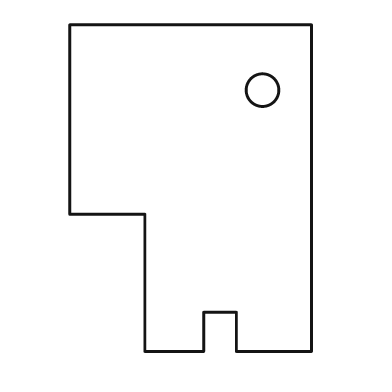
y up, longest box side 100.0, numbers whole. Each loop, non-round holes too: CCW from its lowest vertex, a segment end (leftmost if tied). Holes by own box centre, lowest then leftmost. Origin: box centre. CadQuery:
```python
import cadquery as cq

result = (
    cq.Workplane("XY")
    .moveTo(-14.0, -50.0)
    .lineTo(4.0, -50.0)
    .lineTo(4.0, -38.0)
    .lineTo(14.0, -38.0)
    .lineTo(14.0, -50.0)
    .lineTo(37.0, -50.0)
    .lineTo(37.0, 50.0)
    .lineTo(-37.0, 50.0)
    .lineTo(-37.0, -8.0)
    .lineTo(-14.0, -8.0)
    .close()
    .moveTo(22.0, 30.0)
    .circle(5.0)
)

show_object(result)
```